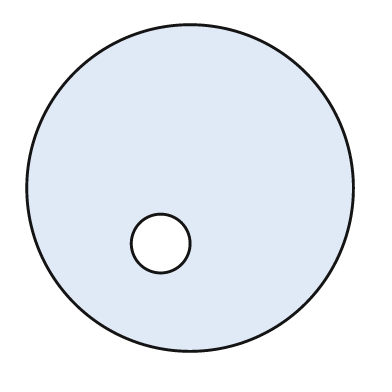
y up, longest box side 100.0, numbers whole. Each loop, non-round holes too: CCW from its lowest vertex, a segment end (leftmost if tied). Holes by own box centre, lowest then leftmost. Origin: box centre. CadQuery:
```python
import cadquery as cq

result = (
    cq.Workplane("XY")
    .moveTo(0.0, 0.0)
    .circle(50.0)
    .moveTo(-9.0, -17.0)
    .circle(9.0)
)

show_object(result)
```